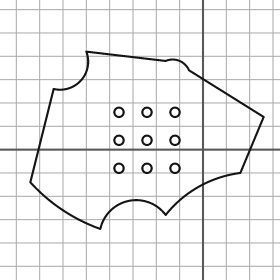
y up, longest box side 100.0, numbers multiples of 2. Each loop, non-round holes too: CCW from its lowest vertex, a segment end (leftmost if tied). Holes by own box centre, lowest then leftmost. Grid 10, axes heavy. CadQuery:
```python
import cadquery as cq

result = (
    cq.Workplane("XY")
    .moveTo(-44.0, -34.0)
    .threePointArc((-32.0, -22.0), (-16.0, -28.0))
    .threePointArc((-2.0, -16.0), (16.0, -10.0))
    .lineTo(26.0, 14.0)
    .lineTo(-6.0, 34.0)
    .threePointArc((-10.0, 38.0), (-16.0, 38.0))
    .lineTo(-50.0, 42.0)
    .threePointArc((-52.0, 30.0), (-64.0, 26.0))
    .lineTo(-74.0, -14.0)
    .threePointArc((-60.0, -26.0), (-44.0, -34.0))
    .close()
    .moveTo(-36.0, -8.0)
    .circle(2.0)
    .moveTo(-24.0, -8.0)
    .circle(2.0)
    .moveTo(-12.0, -8.0)
    .circle(2.0)
    .moveTo(-36.0, 4.0)
    .circle(2.0)
    .moveTo(-24.0, 4.0)
    .circle(2.0)
    .moveTo(-12.0, 4.0)
    .circle(2.0)
    .moveTo(-36.0, 16.0)
    .circle(2.0)
    .moveTo(-24.0, 16.0)
    .circle(2.0)
    .moveTo(-12.0, 16.0)
    .circle(2.0)
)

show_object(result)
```